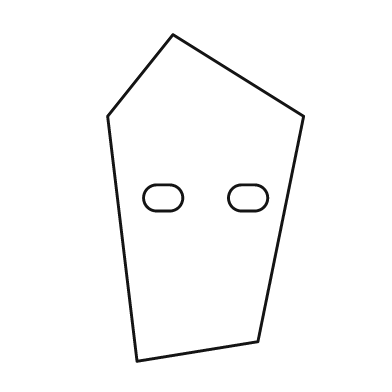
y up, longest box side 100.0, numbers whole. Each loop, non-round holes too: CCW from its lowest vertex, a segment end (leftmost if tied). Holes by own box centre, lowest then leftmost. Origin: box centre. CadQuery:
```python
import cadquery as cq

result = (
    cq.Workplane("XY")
    .moveTo(-21.0, -50.0)
    .lineTo(16.0, -44.0)
    .lineTo(30.0, 25.0)
    .lineTo(-10.0, 50.0)
    .lineTo(-30.0, 25.0)
    .close()
    .moveTo(-15.0, -4.0)
    .lineTo(-11.0, -4.0)
    .threePointArc((-7.0, 0.0), (-11.0, 4.0))
    .lineTo(-15.0, 4.0)
    .threePointArc((-19.0, 0.0), (-15.0, -4.0))
    .close()
    .moveTo(11.0, -4.0)
    .lineTo(15.0, -4.0)
    .threePointArc((19.0, 0.0), (15.0, 4.0))
    .lineTo(11.0, 4.0)
    .threePointArc((7.0, 0.0), (11.0, -4.0))
    .close()
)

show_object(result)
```